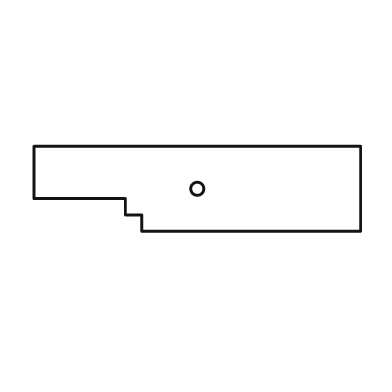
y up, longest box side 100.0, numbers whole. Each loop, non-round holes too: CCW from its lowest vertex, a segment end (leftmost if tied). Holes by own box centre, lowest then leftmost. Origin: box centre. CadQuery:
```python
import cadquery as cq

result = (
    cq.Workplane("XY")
    .moveTo(-17.0, -13.0)
    .lineTo(50.0, -13.0)
    .lineTo(50.0, 13.0)
    .lineTo(-50.0, 13.0)
    .lineTo(-50.0, -3.0)
    .lineTo(-22.0, -3.0)
    .lineTo(-22.0, -8.0)
    .lineTo(-17.0, -8.0)
    .close()
    .moveTo(0.0, 0.0)
    .circle(2.0)
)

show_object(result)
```